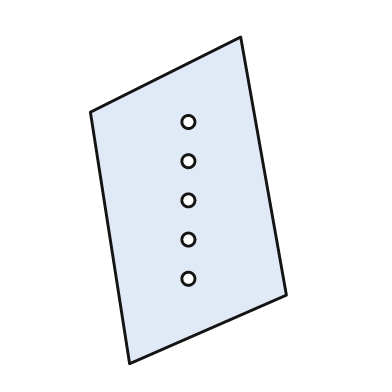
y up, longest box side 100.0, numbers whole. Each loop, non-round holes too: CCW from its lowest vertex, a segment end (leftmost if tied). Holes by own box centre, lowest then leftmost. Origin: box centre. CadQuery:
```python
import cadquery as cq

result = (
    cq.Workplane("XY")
    .moveTo(-18.0, -50.0)
    .lineTo(30.0, -29.0)
    .lineTo(16.0, 50.0)
    .lineTo(-30.0, 27.0)
    .close()
    .moveTo(0.0, -24.0)
    .circle(2.0)
    .moveTo(0.0, -12.0)
    .circle(2.0)
    .moveTo(0.0, 0.0)
    .circle(2.0)
    .moveTo(0.0, 12.0)
    .circle(2.0)
    .moveTo(0.0, 24.0)
    .circle(2.0)
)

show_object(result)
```